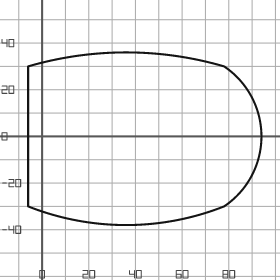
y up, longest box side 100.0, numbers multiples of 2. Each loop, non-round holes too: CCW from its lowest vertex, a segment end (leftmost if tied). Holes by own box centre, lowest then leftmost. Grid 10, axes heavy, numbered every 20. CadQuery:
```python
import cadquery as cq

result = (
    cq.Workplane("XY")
    .moveTo(-6.0, -30.0)
    .threePointArc((36.0, -38.0), (78.0, -30.0))
    .threePointArc((94.0, 0.0), (78.0, 30.0))
    .threePointArc((36.0, 36.0), (-6.0, 30.0))
    .close()
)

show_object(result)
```